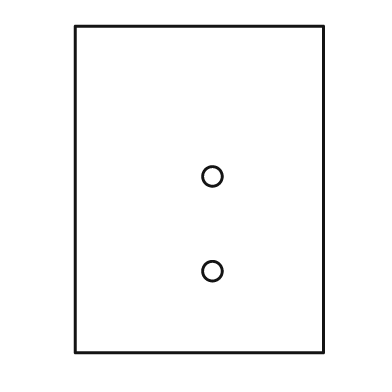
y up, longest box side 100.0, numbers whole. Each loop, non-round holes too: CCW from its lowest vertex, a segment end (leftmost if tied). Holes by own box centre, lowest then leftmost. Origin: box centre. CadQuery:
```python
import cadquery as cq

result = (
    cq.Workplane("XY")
    .moveTo(-38.0, -50.0)
    .lineTo(38.0, -50.0)
    .lineTo(38.0, 50.0)
    .lineTo(-38.0, 50.0)
    .close()
    .moveTo(4.0, -25.0)
    .circle(3.0)
    .moveTo(4.0, 4.0)
    .circle(3.0)
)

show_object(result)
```